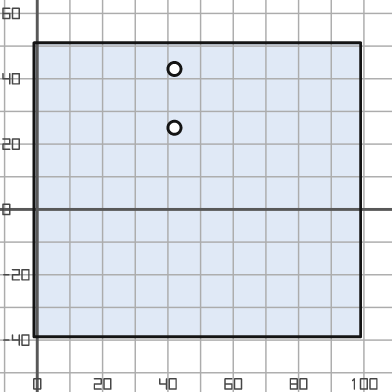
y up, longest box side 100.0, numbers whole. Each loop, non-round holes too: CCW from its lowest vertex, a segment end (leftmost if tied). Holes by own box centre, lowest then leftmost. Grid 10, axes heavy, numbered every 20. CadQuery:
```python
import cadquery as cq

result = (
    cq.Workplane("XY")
    .moveTo(-1.0, -39.0)
    .lineTo(99.0, -39.0)
    .lineTo(99.0, 51.0)
    .lineTo(-1.0, 51.0)
    .close()
    .moveTo(42.0, 25.0)
    .circle(2.0)
    .moveTo(42.0, 43.0)
    .circle(2.0)
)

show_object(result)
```